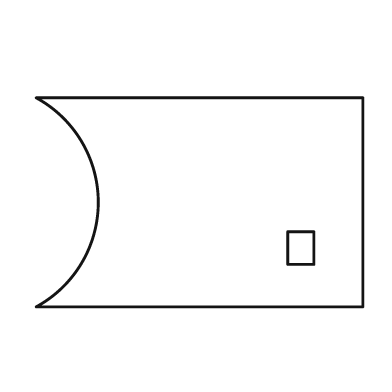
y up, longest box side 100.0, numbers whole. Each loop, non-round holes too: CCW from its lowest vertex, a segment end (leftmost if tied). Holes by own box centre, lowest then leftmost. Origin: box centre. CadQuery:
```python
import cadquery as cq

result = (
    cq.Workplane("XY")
    .moveTo(-50.0, -32.0)
    .lineTo(50.0, -32.0)
    .lineTo(50.0, 32.0)
    .lineTo(-50.0, 32.0)
    .threePointArc((-31.0, 0.0), (-50.0, -32.0))
    .close()
    .moveTo(27.0, -19.0)
    .lineTo(35.0, -19.0)
    .lineTo(35.0, -9.0)
    .lineTo(27.0, -9.0)
    .close()
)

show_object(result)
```